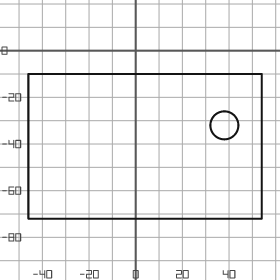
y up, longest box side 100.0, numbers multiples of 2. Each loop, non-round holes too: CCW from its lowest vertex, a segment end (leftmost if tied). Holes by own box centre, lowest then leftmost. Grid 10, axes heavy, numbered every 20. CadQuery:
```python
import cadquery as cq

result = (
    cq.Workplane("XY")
    .moveTo(-46.0, -72.0)
    .lineTo(54.0, -72.0)
    .lineTo(54.0, -10.0)
    .lineTo(-46.0, -10.0)
    .close()
    .moveTo(38.0, -32.0)
    .circle(6.0)
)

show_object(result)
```